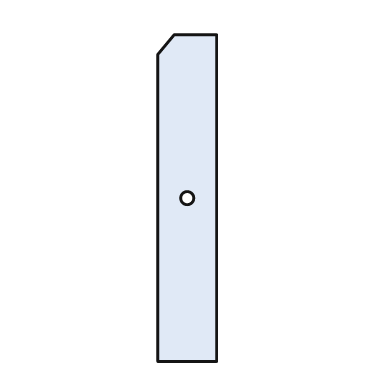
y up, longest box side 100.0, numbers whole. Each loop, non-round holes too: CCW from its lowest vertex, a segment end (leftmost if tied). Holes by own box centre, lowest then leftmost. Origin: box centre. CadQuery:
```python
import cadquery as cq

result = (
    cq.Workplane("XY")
    .moveTo(-9.0, -50.0)
    .lineTo(9.0, -50.0)
    .lineTo(9.0, 50.0)
    .lineTo(-4.0, 50.0)
    .lineTo(-9.0, 44.0)
    .close()
    .moveTo(0.0, 0.0)
    .circle(2.0)
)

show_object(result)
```